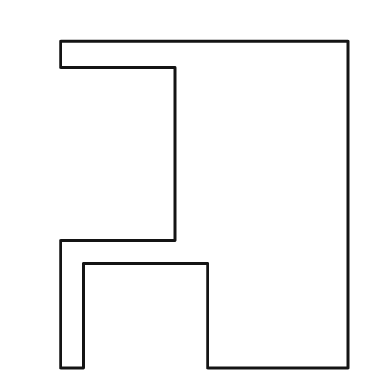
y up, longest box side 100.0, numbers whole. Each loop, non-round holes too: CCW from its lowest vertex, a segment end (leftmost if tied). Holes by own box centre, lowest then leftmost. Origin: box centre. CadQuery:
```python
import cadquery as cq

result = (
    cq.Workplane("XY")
    .moveTo(-44.0, -50.0)
    .lineTo(-37.0, -50.0)
    .lineTo(-37.0, -18.0)
    .lineTo(1.0, -18.0)
    .lineTo(1.0, -50.0)
    .lineTo(44.0, -50.0)
    .lineTo(44.0, 50.0)
    .lineTo(-44.0, 50.0)
    .lineTo(-44.0, 42.0)
    .lineTo(-9.0, 42.0)
    .lineTo(-9.0, -11.0)
    .lineTo(-44.0, -11.0)
    .close()
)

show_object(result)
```